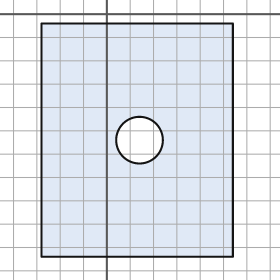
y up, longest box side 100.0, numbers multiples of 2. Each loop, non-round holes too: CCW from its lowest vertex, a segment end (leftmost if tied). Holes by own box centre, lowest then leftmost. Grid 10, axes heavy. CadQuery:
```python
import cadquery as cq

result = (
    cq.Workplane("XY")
    .moveTo(-28.0, -104.0)
    .lineTo(54.0, -104.0)
    .lineTo(54.0, -4.0)
    .lineTo(-28.0, -4.0)
    .close()
    .moveTo(14.0, -54.0)
    .circle(10.0)
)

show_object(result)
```